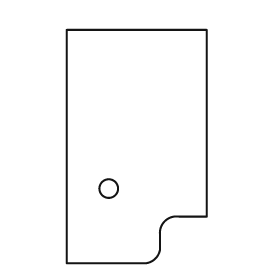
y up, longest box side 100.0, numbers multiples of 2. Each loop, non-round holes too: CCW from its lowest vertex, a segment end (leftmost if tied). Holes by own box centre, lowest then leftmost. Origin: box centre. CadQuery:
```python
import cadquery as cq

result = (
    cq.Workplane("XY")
    .moveTo(-30.0, -50.0)
    .lineTo(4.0, -50.0)
    .threePointArc((8.0, -48.0), (10.0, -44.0))
    .lineTo(10.0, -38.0)
    .threePointArc((12.0, -32.0), (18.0, -30.0))
    .lineTo(30.0, -30.0)
    .lineTo(30.0, 50.0)
    .lineTo(-30.0, 50.0)
    .close()
    .moveTo(-12.0, -18.0)
    .circle(4.0)
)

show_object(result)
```